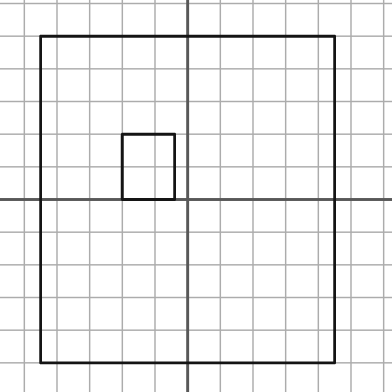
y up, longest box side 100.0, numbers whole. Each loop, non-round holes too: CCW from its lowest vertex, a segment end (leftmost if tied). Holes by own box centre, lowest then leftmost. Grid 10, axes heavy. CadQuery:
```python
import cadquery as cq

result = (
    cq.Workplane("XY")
    .moveTo(-45.0, -50.0)
    .lineTo(45.0, -50.0)
    .lineTo(45.0, 50.0)
    .lineTo(-45.0, 50.0)
    .close()
    .moveTo(-20.0, 0.0)
    .lineTo(-4.0, 0.0)
    .lineTo(-4.0, 20.0)
    .lineTo(-20.0, 20.0)
    .close()
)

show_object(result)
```